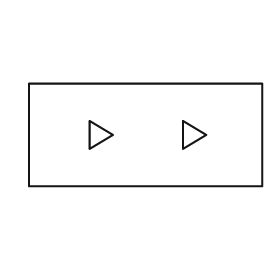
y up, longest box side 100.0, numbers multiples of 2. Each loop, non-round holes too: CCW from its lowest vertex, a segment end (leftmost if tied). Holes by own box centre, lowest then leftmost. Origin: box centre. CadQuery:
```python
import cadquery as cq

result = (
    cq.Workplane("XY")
    .moveTo(-50.0, -22.0)
    .lineTo(50.0, -22.0)
    .lineTo(50.0, 22.0)
    .lineTo(-50.0, 22.0)
    .close()
    .moveTo(-24.0, -6.0)
    .lineTo(-14.0, 0.0)
    .lineTo(-24.0, 6.0)
    .close()
    .moveTo(16.0, -6.0)
    .lineTo(26.0, 0.0)
    .lineTo(16.0, 6.0)
    .close()
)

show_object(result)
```